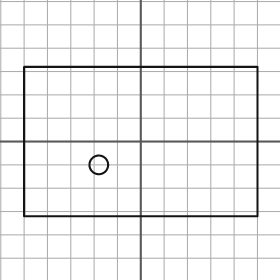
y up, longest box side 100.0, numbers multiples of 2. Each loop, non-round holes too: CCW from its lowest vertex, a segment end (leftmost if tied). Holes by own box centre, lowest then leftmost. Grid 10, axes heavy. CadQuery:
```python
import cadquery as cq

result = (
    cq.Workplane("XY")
    .moveTo(-50.0, -32.0)
    .lineTo(50.0, -32.0)
    .lineTo(50.0, 32.0)
    .lineTo(-50.0, 32.0)
    .close()
    .moveTo(-18.0, -10.0)
    .circle(4.0)
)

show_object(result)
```